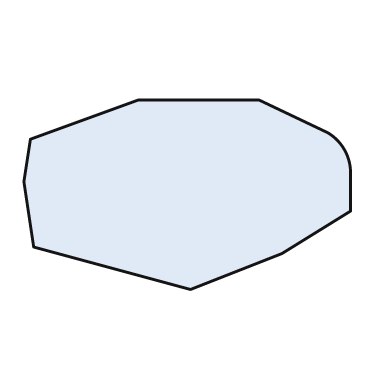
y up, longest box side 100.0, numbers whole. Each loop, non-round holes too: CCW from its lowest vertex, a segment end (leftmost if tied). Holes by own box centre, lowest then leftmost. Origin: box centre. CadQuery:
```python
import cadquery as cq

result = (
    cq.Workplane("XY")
    .moveTo(1.0, -29.0)
    .lineTo(29.0, -18.0)
    .lineTo(50.0, -5.0)
    .lineTo(50.0, 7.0)
    .threePointArc((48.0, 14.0), (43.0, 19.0))
    .lineTo(22.0, 29.0)
    .lineTo(-15.0, 29.0)
    .lineTo(-48.0, 17.0)
    .lineTo(-50.0, 4.0)
    .lineTo(-47.0, -16.0)
    .close()
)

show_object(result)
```